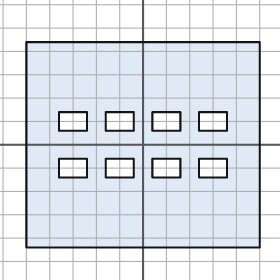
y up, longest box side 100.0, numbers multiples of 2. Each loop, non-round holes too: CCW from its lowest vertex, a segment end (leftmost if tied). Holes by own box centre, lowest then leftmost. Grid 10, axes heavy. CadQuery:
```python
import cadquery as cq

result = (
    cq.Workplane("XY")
    .moveTo(-50.0, -44.0)
    .lineTo(50.0, -44.0)
    .lineTo(50.0, 44.0)
    .lineTo(-50.0, 44.0)
    .close()
    .moveTo(-36.0, -14.0)
    .lineTo(-24.0, -14.0)
    .lineTo(-24.0, -6.0)
    .lineTo(-36.0, -6.0)
    .close()
    .moveTo(-16.0, -14.0)
    .lineTo(-4.0, -14.0)
    .lineTo(-4.0, -6.0)
    .lineTo(-16.0, -6.0)
    .close()
    .moveTo(4.0, -14.0)
    .lineTo(16.0, -14.0)
    .lineTo(16.0, -6.0)
    .lineTo(4.0, -6.0)
    .close()
    .moveTo(24.0, -14.0)
    .lineTo(36.0, -14.0)
    .lineTo(36.0, -6.0)
    .lineTo(24.0, -6.0)
    .close()
    .moveTo(-36.0, 6.0)
    .lineTo(-24.0, 6.0)
    .lineTo(-24.0, 14.0)
    .lineTo(-36.0, 14.0)
    .close()
    .moveTo(-16.0, 6.0)
    .lineTo(-4.0, 6.0)
    .lineTo(-4.0, 14.0)
    .lineTo(-16.0, 14.0)
    .close()
    .moveTo(4.0, 6.0)
    .lineTo(16.0, 6.0)
    .lineTo(16.0, 14.0)
    .lineTo(4.0, 14.0)
    .close()
    .moveTo(24.0, 6.0)
    .lineTo(36.0, 6.0)
    .lineTo(36.0, 14.0)
    .lineTo(24.0, 14.0)
    .close()
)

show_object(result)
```